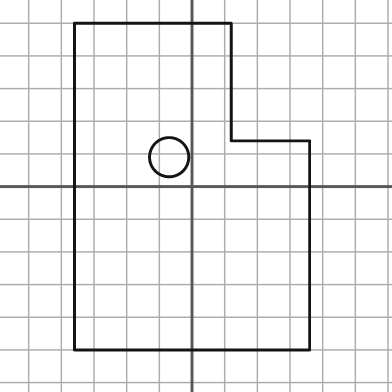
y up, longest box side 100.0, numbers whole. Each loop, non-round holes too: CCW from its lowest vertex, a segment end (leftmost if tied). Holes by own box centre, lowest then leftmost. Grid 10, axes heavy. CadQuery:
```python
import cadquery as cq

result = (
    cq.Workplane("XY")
    .moveTo(-36.0, -50.0)
    .lineTo(36.0, -50.0)
    .lineTo(36.0, 14.0)
    .lineTo(12.0, 14.0)
    .lineTo(12.0, 50.0)
    .lineTo(-36.0, 50.0)
    .close()
    .moveTo(-7.0, 9.0)
    .circle(6.0)
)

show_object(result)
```